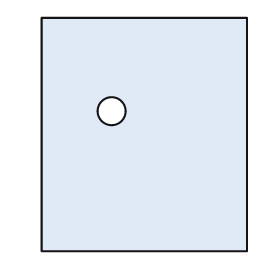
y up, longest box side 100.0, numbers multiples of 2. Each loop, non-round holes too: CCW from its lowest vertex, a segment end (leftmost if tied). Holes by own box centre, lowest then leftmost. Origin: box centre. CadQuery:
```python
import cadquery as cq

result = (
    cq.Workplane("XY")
    .moveTo(-44.0, -50.0)
    .lineTo(44.0, -50.0)
    .lineTo(44.0, 50.0)
    .lineTo(-44.0, 50.0)
    .close()
    .moveTo(-14.0, 10.0)
    .circle(6.0)
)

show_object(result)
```